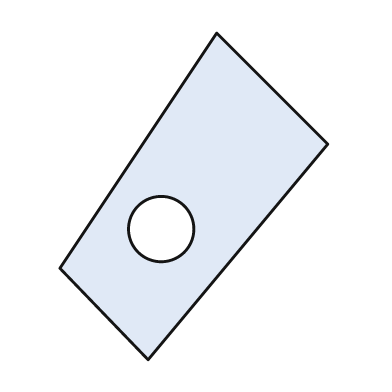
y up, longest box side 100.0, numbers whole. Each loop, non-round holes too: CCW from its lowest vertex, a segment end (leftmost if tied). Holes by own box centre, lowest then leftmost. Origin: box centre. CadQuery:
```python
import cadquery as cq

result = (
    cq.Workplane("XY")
    .moveTo(-14.0, -50.0)
    .lineTo(41.0, 16.0)
    .lineTo(7.0, 50.0)
    .lineTo(-41.0, -22.0)
    .close()
    .moveTo(-10.0, -10.0)
    .circle(10.0)
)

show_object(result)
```